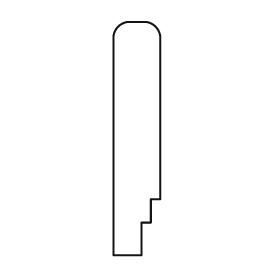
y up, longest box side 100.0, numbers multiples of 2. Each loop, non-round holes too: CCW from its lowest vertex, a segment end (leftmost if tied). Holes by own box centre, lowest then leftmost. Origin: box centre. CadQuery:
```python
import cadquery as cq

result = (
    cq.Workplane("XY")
    .moveTo(-10.0, -50.0)
    .lineTo(2.0, -50.0)
    .lineTo(2.0, -36.0)
    .lineTo(6.0, -36.0)
    .lineTo(6.0, -26.0)
    .lineTo(10.0, -26.0)
    .lineTo(10.0, 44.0)
    .threePointArc((8.0, 48.0), (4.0, 50.0))
    .lineTo(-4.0, 50.0)
    .threePointArc((-8.0, 48.0), (-10.0, 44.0))
    .close()
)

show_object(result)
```